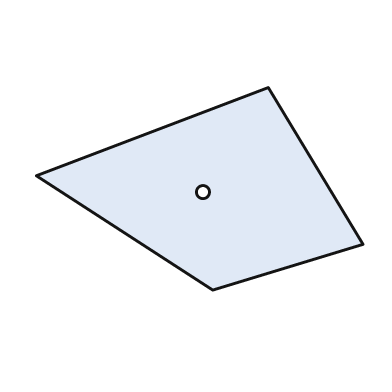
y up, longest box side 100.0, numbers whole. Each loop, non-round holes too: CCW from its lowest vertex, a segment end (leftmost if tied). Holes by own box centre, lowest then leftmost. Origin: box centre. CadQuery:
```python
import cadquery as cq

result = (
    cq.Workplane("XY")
    .moveTo(4.0, -31.0)
    .lineTo(50.0, -17.0)
    .lineTo(21.0, 31.0)
    .lineTo(-50.0, 4.0)
    .close()
    .moveTo(1.0, -1.0)
    .circle(2.0)
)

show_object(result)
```